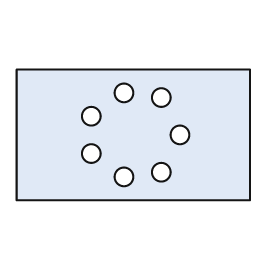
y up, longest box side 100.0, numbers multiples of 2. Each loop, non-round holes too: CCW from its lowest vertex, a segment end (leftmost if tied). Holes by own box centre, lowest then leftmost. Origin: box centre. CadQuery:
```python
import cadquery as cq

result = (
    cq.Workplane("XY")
    .moveTo(-50.0, -28.0)
    .lineTo(50.0, -28.0)
    .lineTo(50.0, 28.0)
    .lineTo(-50.0, 28.0)
    .close()
    .moveTo(-4.0, -18.0)
    .circle(4.0)
    .moveTo(12.0, -16.0)
    .circle(4.0)
    .moveTo(-18.0, -8.0)
    .circle(4.0)
    .moveTo(20.0, 0.0)
    .circle(4.0)
    .moveTo(-18.0, 8.0)
    .circle(4.0)
    .moveTo(12.0, 16.0)
    .circle(4.0)
    .moveTo(-4.0, 18.0)
    .circle(4.0)
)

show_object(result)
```